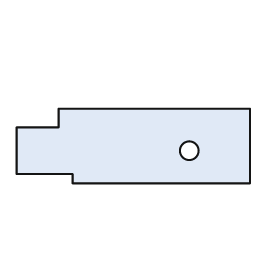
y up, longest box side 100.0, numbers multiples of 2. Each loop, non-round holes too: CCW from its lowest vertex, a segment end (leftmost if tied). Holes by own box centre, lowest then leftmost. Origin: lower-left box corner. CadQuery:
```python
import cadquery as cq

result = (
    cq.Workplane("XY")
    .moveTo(24.0, 0.0)
    .lineTo(100.0, 0.0)
    .lineTo(100.0, 32.0)
    .lineTo(18.0, 32.0)
    .lineTo(18.0, 24.0)
    .lineTo(0.0, 24.0)
    .lineTo(0.0, 4.0)
    .lineTo(24.0, 4.0)
    .close()
    .moveTo(74.0, 14.0)
    .circle(4.0)
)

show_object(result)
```